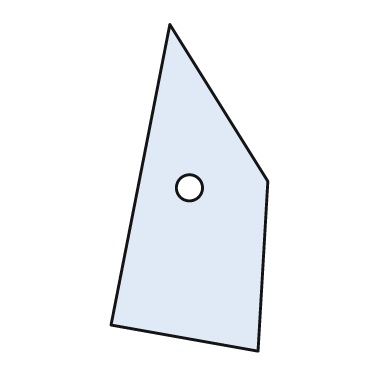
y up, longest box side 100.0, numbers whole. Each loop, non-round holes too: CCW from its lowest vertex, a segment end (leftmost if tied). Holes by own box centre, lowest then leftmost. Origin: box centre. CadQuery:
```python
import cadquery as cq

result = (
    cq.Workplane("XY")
    .moveTo(21.0, -50.0)
    .lineTo(24.0, 2.0)
    .lineTo(-6.0, 50.0)
    .lineTo(-24.0, -42.0)
    .close()
    .moveTo(0.0, 0.0)
    .circle(4.0)
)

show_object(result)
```